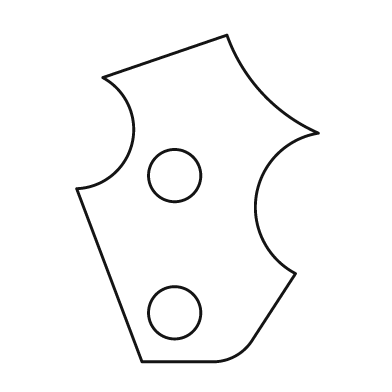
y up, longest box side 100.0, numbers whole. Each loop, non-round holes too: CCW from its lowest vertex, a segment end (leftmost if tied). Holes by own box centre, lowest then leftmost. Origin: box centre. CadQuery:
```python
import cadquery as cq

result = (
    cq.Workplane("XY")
    .moveTo(-17.0, -50.0)
    .lineTo(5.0, -50.0)
    .threePointArc((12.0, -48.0), (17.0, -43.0))
    .lineTo(30.0, -23.0)
    .threePointArc((18.0, 1.0), (37.0, 20.0))
    .threePointArc((20.0, 32.0), (9.0, 50.0))
    .lineTo(-29.0, 37.0)
    .threePointArc((-20.0, 17.0), (-37.0, 3.0))
    .close()
    .moveTo(-7.0, -35.0)
    .circle(8.0)
    .moveTo(-7.0, 7.0)
    .circle(8.0)
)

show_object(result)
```